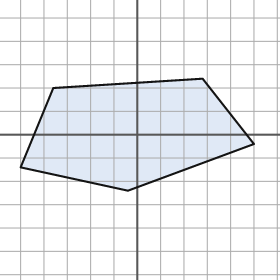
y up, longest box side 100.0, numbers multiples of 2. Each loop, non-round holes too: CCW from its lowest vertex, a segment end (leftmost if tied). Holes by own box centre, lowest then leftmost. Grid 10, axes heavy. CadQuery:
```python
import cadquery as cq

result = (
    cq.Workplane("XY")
    .moveTo(-4.0, -24.0)
    .lineTo(50.0, -4.0)
    .lineTo(28.0, 24.0)
    .lineTo(-36.0, 20.0)
    .lineTo(-50.0, -14.0)
    .close()
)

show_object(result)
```